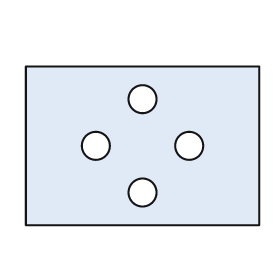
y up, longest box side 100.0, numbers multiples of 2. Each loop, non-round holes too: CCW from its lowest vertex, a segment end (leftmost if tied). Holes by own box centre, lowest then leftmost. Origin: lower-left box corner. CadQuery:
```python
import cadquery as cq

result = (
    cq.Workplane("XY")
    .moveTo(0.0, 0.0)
    .lineTo(100.0, 0.0)
    .lineTo(100.0, 68.0)
    .lineTo(0.0, 68.0)
    .close()
    .moveTo(50.0, 14.0)
    .circle(6.0)
    .moveTo(30.0, 34.0)
    .circle(6.0)
    .moveTo(70.0, 34.0)
    .circle(6.0)
    .moveTo(50.0, 54.0)
    .circle(6.0)
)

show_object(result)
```